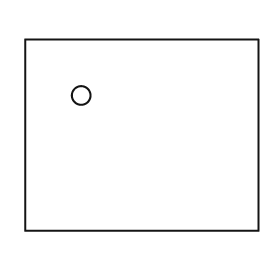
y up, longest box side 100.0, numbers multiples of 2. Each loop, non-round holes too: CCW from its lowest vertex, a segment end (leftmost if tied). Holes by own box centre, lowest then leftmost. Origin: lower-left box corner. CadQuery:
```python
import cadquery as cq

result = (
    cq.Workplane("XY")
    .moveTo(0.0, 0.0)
    .lineTo(100.0, 0.0)
    .lineTo(100.0, 82.0)
    .lineTo(0.0, 82.0)
    .close()
    .moveTo(24.0, 58.0)
    .circle(4.0)
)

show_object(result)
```